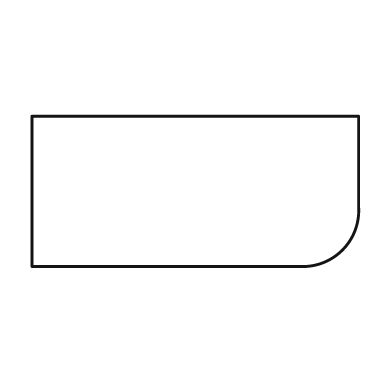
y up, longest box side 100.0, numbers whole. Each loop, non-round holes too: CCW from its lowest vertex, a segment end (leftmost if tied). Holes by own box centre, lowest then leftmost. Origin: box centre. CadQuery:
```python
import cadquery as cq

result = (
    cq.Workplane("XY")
    .moveTo(-50.0, -23.0)
    .lineTo(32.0, -23.0)
    .threePointArc((45.0, -18.0), (50.0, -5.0))
    .lineTo(50.0, 23.0)
    .lineTo(-50.0, 23.0)
    .close()
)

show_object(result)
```